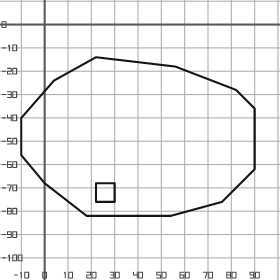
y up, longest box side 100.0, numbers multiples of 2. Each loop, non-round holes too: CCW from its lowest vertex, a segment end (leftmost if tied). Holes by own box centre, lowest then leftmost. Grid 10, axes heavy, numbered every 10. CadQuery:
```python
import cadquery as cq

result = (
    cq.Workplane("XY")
    .moveTo(18.0, -82.0)
    .lineTo(54.0, -82.0)
    .lineTo(76.0, -76.0)
    .lineTo(90.0, -62.0)
    .lineTo(90.0, -36.0)
    .lineTo(82.0, -28.0)
    .lineTo(56.0, -18.0)
    .lineTo(22.0, -14.0)
    .lineTo(4.0, -24.0)
    .lineTo(-10.0, -40.0)
    .lineTo(-10.0, -56.0)
    .lineTo(0.0, -68.0)
    .close()
    .moveTo(22.0, -76.0)
    .lineTo(30.0, -76.0)
    .lineTo(30.0, -68.0)
    .lineTo(22.0, -68.0)
    .close()
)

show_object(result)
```